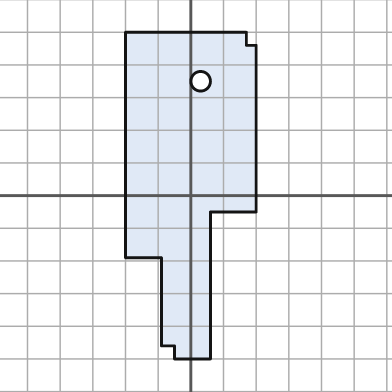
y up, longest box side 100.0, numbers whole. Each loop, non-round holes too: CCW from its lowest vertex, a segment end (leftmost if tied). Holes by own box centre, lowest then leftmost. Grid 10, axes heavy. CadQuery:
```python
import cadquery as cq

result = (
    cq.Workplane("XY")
    .moveTo(-5.0, -50.0)
    .lineTo(6.0, -50.0)
    .lineTo(6.0, -5.0)
    .lineTo(20.0, -5.0)
    .lineTo(20.0, 46.0)
    .lineTo(17.0, 46.0)
    .lineTo(17.0, 50.0)
    .lineTo(-20.0, 50.0)
    .lineTo(-20.0, -19.0)
    .lineTo(-9.0, -19.0)
    .lineTo(-9.0, -46.0)
    .lineTo(-5.0, -46.0)
    .close()
    .moveTo(3.0, 35.0)
    .circle(3.0)
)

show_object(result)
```